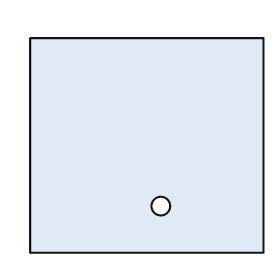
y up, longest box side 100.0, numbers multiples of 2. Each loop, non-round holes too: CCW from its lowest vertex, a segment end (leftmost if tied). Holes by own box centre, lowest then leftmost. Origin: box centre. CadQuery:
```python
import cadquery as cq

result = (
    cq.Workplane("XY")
    .moveTo(-50.0, -46.0)
    .lineTo(50.0, -46.0)
    .lineTo(50.0, 46.0)
    .lineTo(-50.0, 46.0)
    .close()
    .moveTo(6.0, -26.0)
    .circle(4.0)
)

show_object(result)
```